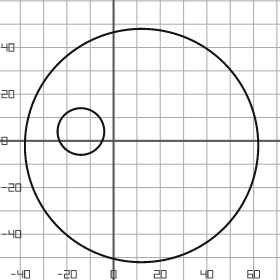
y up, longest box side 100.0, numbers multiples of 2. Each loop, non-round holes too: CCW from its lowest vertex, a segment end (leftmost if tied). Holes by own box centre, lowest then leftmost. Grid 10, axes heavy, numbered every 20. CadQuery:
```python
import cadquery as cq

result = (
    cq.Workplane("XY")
    .moveTo(12.0, -2.0)
    .circle(50.0)
    .moveTo(-14.0, 4.0)
    .circle(10.0)
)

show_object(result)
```